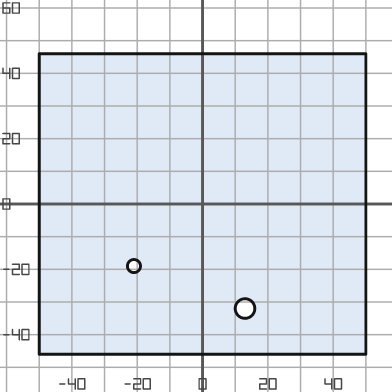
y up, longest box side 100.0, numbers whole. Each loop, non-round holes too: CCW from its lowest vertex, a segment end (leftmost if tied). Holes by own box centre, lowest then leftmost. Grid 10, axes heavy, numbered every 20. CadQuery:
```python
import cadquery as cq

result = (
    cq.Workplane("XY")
    .moveTo(-50.0, -46.0)
    .lineTo(50.0, -46.0)
    .lineTo(50.0, 46.0)
    .lineTo(-50.0, 46.0)
    .close()
    .moveTo(13.0, -32.0)
    .circle(3.0)
    .moveTo(-21.0, -19.0)
    .circle(2.0)
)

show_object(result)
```